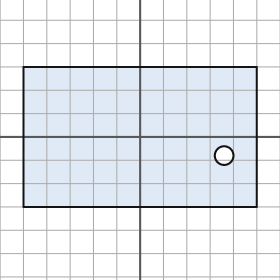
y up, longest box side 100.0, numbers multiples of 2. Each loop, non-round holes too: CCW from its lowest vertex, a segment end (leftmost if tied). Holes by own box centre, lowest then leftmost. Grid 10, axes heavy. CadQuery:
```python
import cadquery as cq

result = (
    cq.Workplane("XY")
    .moveTo(-50.0, -30.0)
    .lineTo(50.0, -30.0)
    .lineTo(50.0, 30.0)
    .lineTo(-50.0, 30.0)
    .close()
    .moveTo(36.0, -8.0)
    .circle(4.0)
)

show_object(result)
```